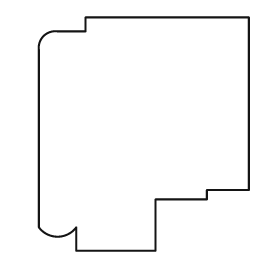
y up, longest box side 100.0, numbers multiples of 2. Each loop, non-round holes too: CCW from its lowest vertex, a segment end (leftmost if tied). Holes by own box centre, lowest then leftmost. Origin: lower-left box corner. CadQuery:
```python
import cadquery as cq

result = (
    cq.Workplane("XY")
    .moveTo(16.0, 0.0)
    .lineTo(50.0, 0.0)
    .lineTo(50.0, 22.0)
    .lineTo(72.0, 22.0)
    .lineTo(72.0, 26.0)
    .lineTo(90.0, 26.0)
    .lineTo(90.0, 100.0)
    .lineTo(20.0, 100.0)
    .lineTo(20.0, 94.0)
    .lineTo(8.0, 94.0)
    .threePointArc((2.0, 92.0), (0.0, 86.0))
    .lineTo(0.0, 10.0)
    .threePointArc((8.0, 6.0), (16.0, 10.0))
    .close()
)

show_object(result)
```